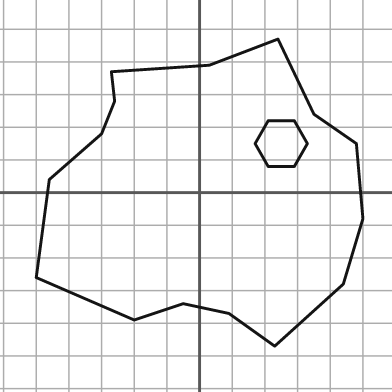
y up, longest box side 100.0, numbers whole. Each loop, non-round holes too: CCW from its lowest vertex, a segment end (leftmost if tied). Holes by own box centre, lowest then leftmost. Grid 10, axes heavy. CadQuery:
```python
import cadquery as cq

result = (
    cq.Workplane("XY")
    .moveTo(23.0, -47.0)
    .lineTo(44.0, -28.0)
    .lineTo(50.0, -8.0)
    .lineTo(48.0, 15.0)
    .lineTo(35.0, 24.0)
    .lineTo(24.0, 47.0)
    .lineTo(3.0, 39.0)
    .lineTo(-27.0, 37.0)
    .lineTo(-26.0, 28.0)
    .lineTo(-30.0, 18.0)
    .lineTo(-46.0, 4.0)
    .lineTo(-50.0, -26.0)
    .lineTo(-20.0, -39.0)
    .lineTo(-5.0, -34.0)
    .lineTo(9.0, -37.0)
    .close()
    .moveTo(21.0, 8.0)
    .lineTo(29.0, 8.0)
    .lineTo(33.0, 15.0)
    .lineTo(29.0, 22.0)
    .lineTo(21.0, 22.0)
    .lineTo(17.0, 15.0)
    .close()
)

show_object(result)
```